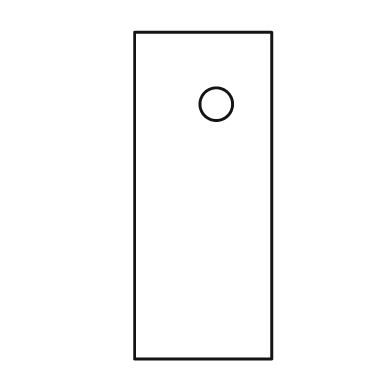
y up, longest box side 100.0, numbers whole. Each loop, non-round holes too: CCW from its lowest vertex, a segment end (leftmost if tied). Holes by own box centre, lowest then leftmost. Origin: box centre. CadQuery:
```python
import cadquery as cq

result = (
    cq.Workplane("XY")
    .moveTo(-21.0, -50.0)
    .lineTo(21.0, -50.0)
    .lineTo(21.0, 50.0)
    .lineTo(-21.0, 50.0)
    .close()
    .moveTo(4.0, 28.0)
    .circle(5.0)
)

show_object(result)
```